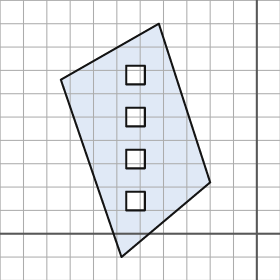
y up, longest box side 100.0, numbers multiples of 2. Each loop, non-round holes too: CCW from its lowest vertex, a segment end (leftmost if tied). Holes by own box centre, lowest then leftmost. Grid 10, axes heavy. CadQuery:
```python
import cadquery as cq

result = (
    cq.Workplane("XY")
    .moveTo(-58.0, -10.0)
    .lineTo(-20.0, 22.0)
    .lineTo(-42.0, 90.0)
    .lineTo(-84.0, 66.0)
    .close()
    .moveTo(-56.0, 10.0)
    .lineTo(-48.0, 10.0)
    .lineTo(-48.0, 18.0)
    .lineTo(-56.0, 18.0)
    .close()
    .moveTo(-56.0, 28.0)
    .lineTo(-48.0, 28.0)
    .lineTo(-48.0, 36.0)
    .lineTo(-56.0, 36.0)
    .close()
    .moveTo(-56.0, 46.0)
    .lineTo(-48.0, 46.0)
    .lineTo(-48.0, 54.0)
    .lineTo(-56.0, 54.0)
    .close()
    .moveTo(-56.0, 64.0)
    .lineTo(-48.0, 64.0)
    .lineTo(-48.0, 72.0)
    .lineTo(-56.0, 72.0)
    .close()
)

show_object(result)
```